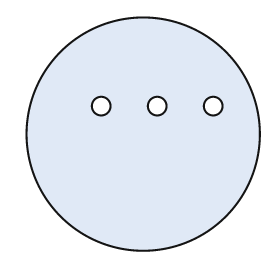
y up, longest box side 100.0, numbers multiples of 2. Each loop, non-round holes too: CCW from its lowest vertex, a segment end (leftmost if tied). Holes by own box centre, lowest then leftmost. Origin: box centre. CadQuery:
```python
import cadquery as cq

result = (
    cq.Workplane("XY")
    .moveTo(0.0, 0.0)
    .circle(50.0)
    .moveTo(-18.0, 12.0)
    .circle(4.0)
    .moveTo(6.0, 12.0)
    .circle(4.0)
    .moveTo(30.0, 12.0)
    .circle(4.0)
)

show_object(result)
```